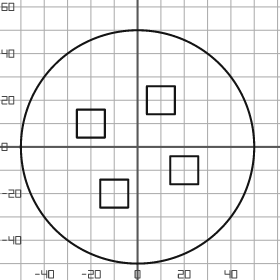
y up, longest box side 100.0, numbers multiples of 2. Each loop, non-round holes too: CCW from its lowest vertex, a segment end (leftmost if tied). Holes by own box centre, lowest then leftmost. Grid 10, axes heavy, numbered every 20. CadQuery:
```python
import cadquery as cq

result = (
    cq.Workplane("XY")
    .moveTo(0.0, 0.0)
    .circle(50.0)
    .moveTo(-16.0, -26.0)
    .lineTo(-4.0, -26.0)
    .lineTo(-4.0, -14.0)
    .lineTo(-16.0, -14.0)
    .close()
    .moveTo(14.0, -16.0)
    .lineTo(26.0, -16.0)
    .lineTo(26.0, -4.0)
    .lineTo(14.0, -4.0)
    .close()
    .moveTo(-26.0, 4.0)
    .lineTo(-14.0, 4.0)
    .lineTo(-14.0, 16.0)
    .lineTo(-26.0, 16.0)
    .close()
    .moveTo(4.0, 14.0)
    .lineTo(16.0, 14.0)
    .lineTo(16.0, 26.0)
    .lineTo(4.0, 26.0)
    .close()
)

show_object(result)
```